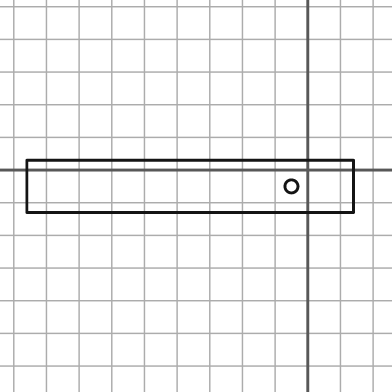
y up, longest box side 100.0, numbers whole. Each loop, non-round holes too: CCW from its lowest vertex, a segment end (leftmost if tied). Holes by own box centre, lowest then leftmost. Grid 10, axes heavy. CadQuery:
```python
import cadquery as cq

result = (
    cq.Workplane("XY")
    .moveTo(-86.0, -13.0)
    .lineTo(14.0, -13.0)
    .lineTo(14.0, 3.0)
    .lineTo(-86.0, 3.0)
    .close()
    .moveTo(-5.0, -5.0)
    .circle(2.0)
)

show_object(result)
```